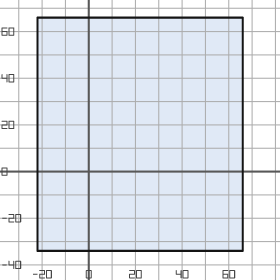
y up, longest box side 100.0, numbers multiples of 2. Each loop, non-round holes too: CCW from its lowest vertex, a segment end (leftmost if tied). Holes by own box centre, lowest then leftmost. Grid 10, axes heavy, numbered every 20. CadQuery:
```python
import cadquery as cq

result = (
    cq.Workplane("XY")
    .moveTo(-22.0, -34.0)
    .lineTo(66.0, -34.0)
    .lineTo(66.0, 66.0)
    .lineTo(-22.0, 66.0)
    .close()
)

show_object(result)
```